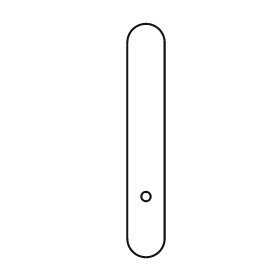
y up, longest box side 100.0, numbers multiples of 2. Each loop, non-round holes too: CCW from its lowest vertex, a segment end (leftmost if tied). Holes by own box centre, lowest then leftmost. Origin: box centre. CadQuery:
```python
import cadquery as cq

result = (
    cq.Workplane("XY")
    .moveTo(-8.0, -42.0)
    .threePointArc((0.0, -50.0), (8.0, -42.0))
    .lineTo(8.0, 42.0)
    .threePointArc((0.0, 50.0), (-8.0, 42.0))
    .close()
    .moveTo(0.0, -24.0)
    .circle(2.0)
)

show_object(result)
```